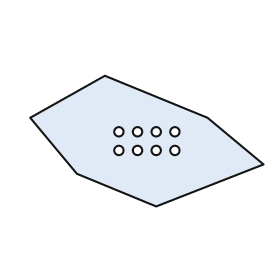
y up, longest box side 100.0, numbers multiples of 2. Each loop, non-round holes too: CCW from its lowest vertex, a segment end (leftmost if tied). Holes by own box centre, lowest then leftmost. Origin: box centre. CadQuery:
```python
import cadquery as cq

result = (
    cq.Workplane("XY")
    .moveTo(4.0, -28.0)
    .lineTo(50.0, -10.0)
    .lineTo(26.0, 10.0)
    .lineTo(-18.0, 28.0)
    .lineTo(-50.0, 10.0)
    .lineTo(-30.0, -14.0)
    .close()
    .moveTo(-12.0, -4.0)
    .circle(2.0)
    .moveTo(-4.0, -4.0)
    .circle(2.0)
    .moveTo(4.0, -4.0)
    .circle(2.0)
    .moveTo(12.0, -4.0)
    .circle(2.0)
    .moveTo(-12.0, 4.0)
    .circle(2.0)
    .moveTo(-4.0, 4.0)
    .circle(2.0)
    .moveTo(4.0, 4.0)
    .circle(2.0)
    .moveTo(12.0, 4.0)
    .circle(2.0)
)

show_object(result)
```